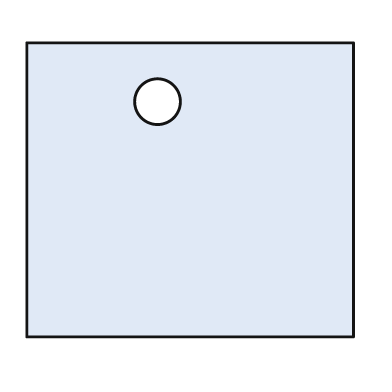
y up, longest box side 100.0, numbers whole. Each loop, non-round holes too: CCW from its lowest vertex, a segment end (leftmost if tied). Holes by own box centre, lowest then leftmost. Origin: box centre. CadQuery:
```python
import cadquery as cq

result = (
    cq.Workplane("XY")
    .moveTo(-50.0, -45.0)
    .lineTo(50.0, -45.0)
    .lineTo(50.0, 45.0)
    .lineTo(-50.0, 45.0)
    .close()
    .moveTo(-10.0, 27.0)
    .circle(7.0)
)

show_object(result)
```